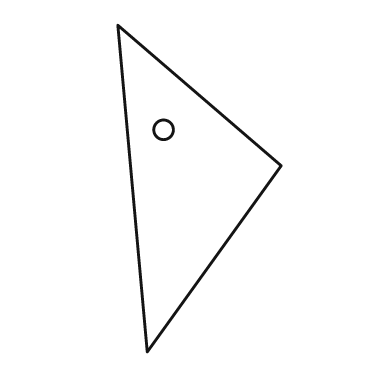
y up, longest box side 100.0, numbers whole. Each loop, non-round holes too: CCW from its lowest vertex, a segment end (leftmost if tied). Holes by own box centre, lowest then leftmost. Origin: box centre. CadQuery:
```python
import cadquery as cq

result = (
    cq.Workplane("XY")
    .moveTo(-16.0, -50.0)
    .lineTo(25.0, 7.0)
    .lineTo(-25.0, 50.0)
    .close()
    .moveTo(-11.0, 18.0)
    .circle(3.0)
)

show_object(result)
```